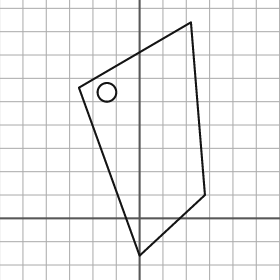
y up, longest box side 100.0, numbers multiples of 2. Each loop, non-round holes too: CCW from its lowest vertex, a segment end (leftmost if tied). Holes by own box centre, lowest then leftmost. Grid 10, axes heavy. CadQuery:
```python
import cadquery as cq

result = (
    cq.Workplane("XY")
    .moveTo(0.0, -16.0)
    .lineTo(28.0, 10.0)
    .lineTo(22.0, 84.0)
    .lineTo(-26.0, 56.0)
    .close()
    .moveTo(-14.0, 54.0)
    .circle(4.0)
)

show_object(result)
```